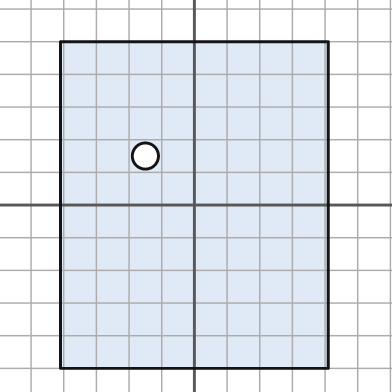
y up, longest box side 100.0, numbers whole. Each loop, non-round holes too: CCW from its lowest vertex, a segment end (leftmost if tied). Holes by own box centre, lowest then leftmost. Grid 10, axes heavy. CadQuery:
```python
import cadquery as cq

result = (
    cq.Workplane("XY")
    .moveTo(-41.0, -50.0)
    .lineTo(41.0, -50.0)
    .lineTo(41.0, 50.0)
    .lineTo(-41.0, 50.0)
    .close()
    .moveTo(-15.0, 15.0)
    .circle(4.0)
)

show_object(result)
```